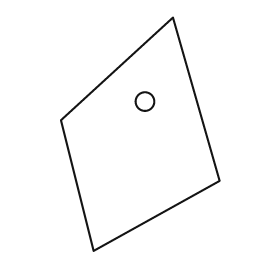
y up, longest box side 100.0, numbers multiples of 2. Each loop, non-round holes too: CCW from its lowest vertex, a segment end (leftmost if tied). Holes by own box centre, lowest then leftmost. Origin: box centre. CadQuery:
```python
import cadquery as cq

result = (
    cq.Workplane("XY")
    .moveTo(-20.0, -50.0)
    .lineTo(34.0, -20.0)
    .lineTo(14.0, 50.0)
    .lineTo(-34.0, 6.0)
    .close()
    .moveTo(2.0, 14.0)
    .circle(4.0)
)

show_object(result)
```